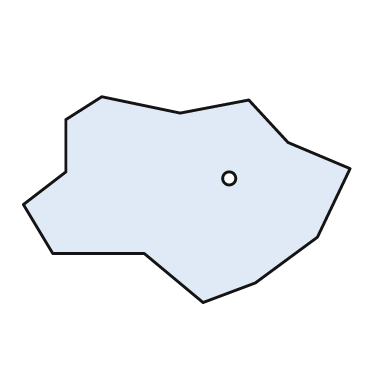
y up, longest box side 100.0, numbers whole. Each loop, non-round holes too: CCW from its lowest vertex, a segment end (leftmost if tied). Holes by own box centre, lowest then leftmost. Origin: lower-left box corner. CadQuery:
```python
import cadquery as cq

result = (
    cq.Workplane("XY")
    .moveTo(55.0, 0.0)
    .lineTo(71.0, 6.0)
    .lineTo(90.0, 20.0)
    .lineTo(100.0, 41.0)
    .lineTo(81.0, 49.0)
    .lineTo(69.0, 62.0)
    .lineTo(48.0, 58.0)
    .lineTo(24.0, 63.0)
    .lineTo(13.0, 56.0)
    .lineTo(13.0, 40.0)
    .lineTo(0.0, 30.0)
    .lineTo(9.0, 15.0)
    .lineTo(37.0, 15.0)
    .close()
    .moveTo(63.0, 38.0)
    .circle(2.0)
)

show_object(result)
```